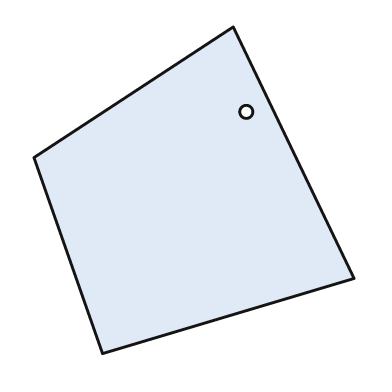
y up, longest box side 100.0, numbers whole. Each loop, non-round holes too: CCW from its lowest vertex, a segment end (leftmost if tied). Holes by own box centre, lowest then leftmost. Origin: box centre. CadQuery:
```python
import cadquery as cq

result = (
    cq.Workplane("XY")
    .moveTo(-28.0, -50.0)
    .lineTo(49.0, -27.0)
    .lineTo(12.0, 50.0)
    .lineTo(-49.0, 10.0)
    .close()
    .moveTo(16.0, 24.0)
    .circle(2.0)
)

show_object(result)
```